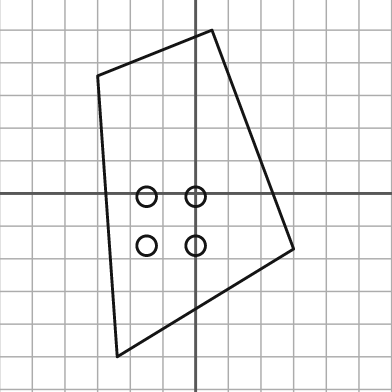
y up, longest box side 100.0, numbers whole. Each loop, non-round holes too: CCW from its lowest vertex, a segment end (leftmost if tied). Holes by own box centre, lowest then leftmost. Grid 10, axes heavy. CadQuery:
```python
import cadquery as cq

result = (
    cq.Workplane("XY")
    .moveTo(-24.0, -50.0)
    .lineTo(30.0, -17.0)
    .lineTo(5.0, 50.0)
    .lineTo(-30.0, 36.0)
    .close()
    .moveTo(-15.0, -16.0)
    .circle(3.0)
    .moveTo(0.0, -16.0)
    .circle(3.0)
    .moveTo(-15.0, -1.0)
    .circle(3.0)
    .moveTo(0.0, -1.0)
    .circle(3.0)
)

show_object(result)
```